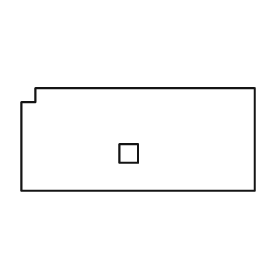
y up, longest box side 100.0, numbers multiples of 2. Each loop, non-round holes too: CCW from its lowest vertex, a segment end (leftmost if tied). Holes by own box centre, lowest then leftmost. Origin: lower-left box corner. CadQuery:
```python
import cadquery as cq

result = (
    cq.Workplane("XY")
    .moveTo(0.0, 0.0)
    .lineTo(100.0, 0.0)
    .lineTo(100.0, 44.0)
    .lineTo(6.0, 44.0)
    .lineTo(6.0, 38.0)
    .lineTo(0.0, 38.0)
    .close()
    .moveTo(42.0, 12.0)
    .lineTo(50.0, 12.0)
    .lineTo(50.0, 20.0)
    .lineTo(42.0, 20.0)
    .close()
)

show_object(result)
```